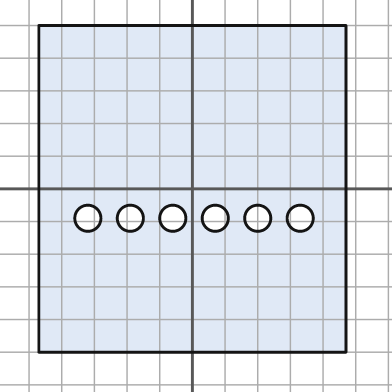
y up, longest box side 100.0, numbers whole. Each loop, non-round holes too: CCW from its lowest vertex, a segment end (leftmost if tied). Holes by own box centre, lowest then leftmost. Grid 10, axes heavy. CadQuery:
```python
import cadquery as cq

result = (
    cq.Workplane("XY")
    .moveTo(-47.0, -50.0)
    .lineTo(47.0, -50.0)
    .lineTo(47.0, 50.0)
    .lineTo(-47.0, 50.0)
    .close()
    .moveTo(-32.0, -9.0)
    .circle(4.0)
    .moveTo(-19.0, -9.0)
    .circle(4.0)
    .moveTo(-6.0, -9.0)
    .circle(4.0)
    .moveTo(7.0, -9.0)
    .circle(4.0)
    .moveTo(20.0, -9.0)
    .circle(4.0)
    .moveTo(33.0, -9.0)
    .circle(4.0)
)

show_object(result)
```